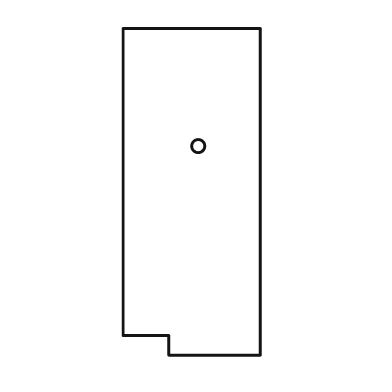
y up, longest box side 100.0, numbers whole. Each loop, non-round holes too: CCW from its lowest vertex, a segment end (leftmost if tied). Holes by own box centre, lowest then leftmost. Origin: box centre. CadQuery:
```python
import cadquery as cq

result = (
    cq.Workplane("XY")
    .moveTo(-7.0, -50.0)
    .lineTo(21.0, -50.0)
    .lineTo(21.0, 50.0)
    .lineTo(-21.0, 50.0)
    .lineTo(-21.0, -44.0)
    .lineTo(-7.0, -44.0)
    .close()
    .moveTo(2.0, 14.0)
    .circle(2.0)
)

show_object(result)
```